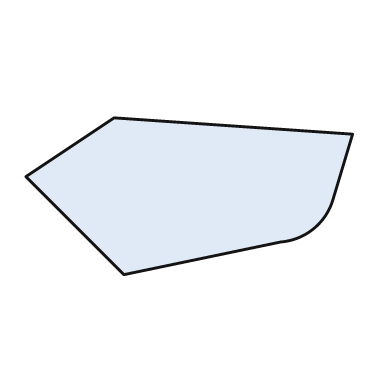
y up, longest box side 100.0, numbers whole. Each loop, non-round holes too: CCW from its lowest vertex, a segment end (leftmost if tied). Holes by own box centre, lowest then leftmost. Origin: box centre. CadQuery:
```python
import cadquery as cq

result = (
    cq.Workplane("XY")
    .moveTo(-20.0, -24.0)
    .lineTo(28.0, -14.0)
    .threePointArc((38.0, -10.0), (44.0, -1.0))
    .lineTo(50.0, 19.0)
    .lineTo(-23.0, 24.0)
    .lineTo(-50.0, 6.0)
    .close()
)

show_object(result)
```